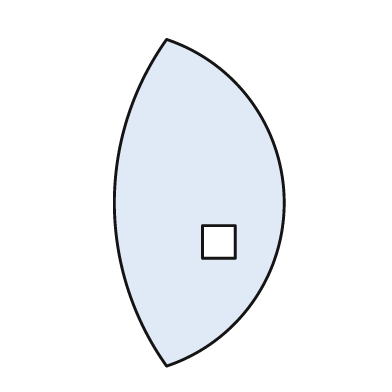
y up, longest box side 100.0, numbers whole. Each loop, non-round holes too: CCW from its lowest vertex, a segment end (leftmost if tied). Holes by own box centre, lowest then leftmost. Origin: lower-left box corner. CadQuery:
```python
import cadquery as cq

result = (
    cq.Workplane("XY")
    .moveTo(16.0, 0.0)
    .threePointArc((52.0, 50.0), (16.0, 100.0))
    .threePointArc((0.0, 50.0), (16.0, 0.0))
    .close()
    .moveTo(27.0, 33.0)
    .lineTo(37.0, 33.0)
    .lineTo(37.0, 43.0)
    .lineTo(27.0, 43.0)
    .close()
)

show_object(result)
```